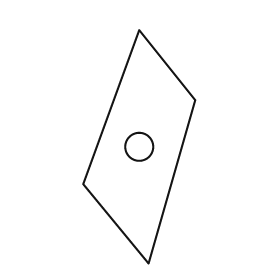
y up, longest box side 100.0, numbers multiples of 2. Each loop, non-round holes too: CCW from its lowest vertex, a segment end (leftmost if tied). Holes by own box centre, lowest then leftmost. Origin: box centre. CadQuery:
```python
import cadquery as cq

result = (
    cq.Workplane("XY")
    .moveTo(4.0, -50.0)
    .lineTo(24.0, 20.0)
    .lineTo(0.0, 50.0)
    .lineTo(-24.0, -16.0)
    .close()
    .moveTo(0.0, 0.0)
    .circle(6.0)
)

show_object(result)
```